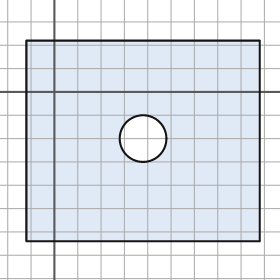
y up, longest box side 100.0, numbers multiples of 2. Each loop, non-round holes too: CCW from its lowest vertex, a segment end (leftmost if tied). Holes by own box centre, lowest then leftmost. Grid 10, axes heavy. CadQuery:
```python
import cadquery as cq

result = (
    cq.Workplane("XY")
    .moveTo(-12.0, -64.0)
    .lineTo(88.0, -64.0)
    .lineTo(88.0, 22.0)
    .lineTo(-12.0, 22.0)
    .close()
    .moveTo(38.0, -20.0)
    .circle(10.0)
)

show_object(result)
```